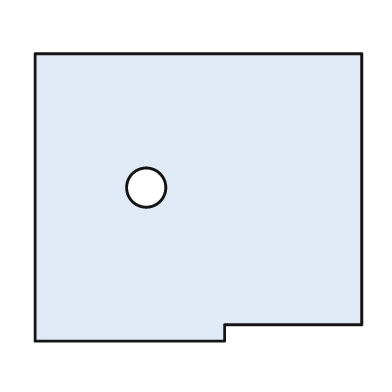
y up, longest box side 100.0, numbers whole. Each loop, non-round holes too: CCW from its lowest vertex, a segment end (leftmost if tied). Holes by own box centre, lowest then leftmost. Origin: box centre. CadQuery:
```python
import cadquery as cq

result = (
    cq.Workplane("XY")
    .moveTo(-50.0, -44.0)
    .lineTo(8.0, -44.0)
    .lineTo(8.0, -39.0)
    .lineTo(50.0, -39.0)
    .lineTo(50.0, 44.0)
    .lineTo(-50.0, 44.0)
    .close()
    .moveTo(-16.0, 3.0)
    .circle(6.0)
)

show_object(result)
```